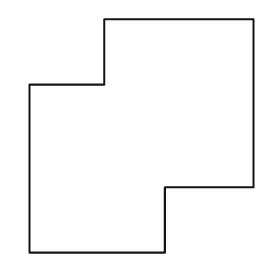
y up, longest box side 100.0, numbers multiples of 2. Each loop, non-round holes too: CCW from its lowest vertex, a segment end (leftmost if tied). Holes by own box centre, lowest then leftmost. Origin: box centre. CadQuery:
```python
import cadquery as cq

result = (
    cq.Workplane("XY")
    .moveTo(-48.0, -50.0)
    .lineTo(10.0, -50.0)
    .lineTo(10.0, -22.0)
    .lineTo(48.0, -22.0)
    .lineTo(48.0, 50.0)
    .lineTo(-16.0, 50.0)
    .lineTo(-16.0, 22.0)
    .lineTo(-48.0, 22.0)
    .close()
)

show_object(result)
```